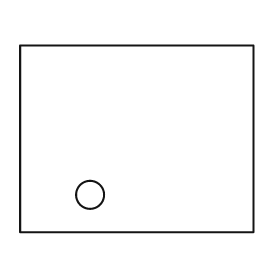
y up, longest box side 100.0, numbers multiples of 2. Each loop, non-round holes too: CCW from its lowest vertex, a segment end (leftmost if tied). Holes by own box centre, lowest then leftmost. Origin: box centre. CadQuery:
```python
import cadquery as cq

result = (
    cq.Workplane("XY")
    .moveTo(-50.0, -40.0)
    .lineTo(50.0, -40.0)
    .lineTo(50.0, 40.0)
    .lineTo(-50.0, 40.0)
    .close()
    .moveTo(-20.0, -24.0)
    .circle(6.0)
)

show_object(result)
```